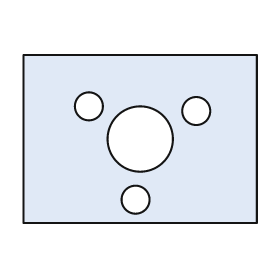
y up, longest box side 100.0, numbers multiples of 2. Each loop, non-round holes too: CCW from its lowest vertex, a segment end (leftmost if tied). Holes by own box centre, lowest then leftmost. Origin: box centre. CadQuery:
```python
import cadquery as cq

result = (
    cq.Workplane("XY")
    .moveTo(-50.0, -36.0)
    .lineTo(50.0, -36.0)
    .lineTo(50.0, 36.0)
    .lineTo(-50.0, 36.0)
    .close()
    .moveTo(-2.0, -26.0)
    .circle(6.0)
    .moveTo(0.0, 0.0)
    .circle(14.0)
    .moveTo(24.0, 12.0)
    .circle(6.0)
    .moveTo(-22.0, 14.0)
    .circle(6.0)
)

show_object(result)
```